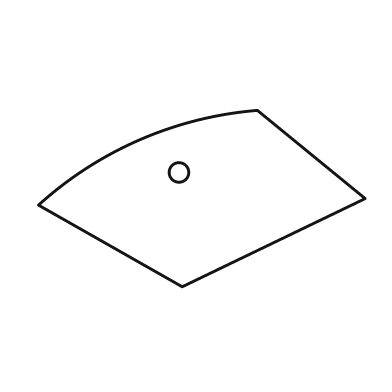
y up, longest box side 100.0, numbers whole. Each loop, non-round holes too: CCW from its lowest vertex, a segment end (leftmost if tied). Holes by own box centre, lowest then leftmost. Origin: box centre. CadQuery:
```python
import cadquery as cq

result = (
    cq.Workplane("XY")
    .moveTo(-6.0, -27.0)
    .lineTo(50.0, 0.0)
    .lineTo(17.0, 27.0)
    .threePointArc((-19.0, 18.0), (-50.0, -2.0))
    .close()
    .moveTo(-7.0, 8.0)
    .circle(3.0)
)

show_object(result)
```